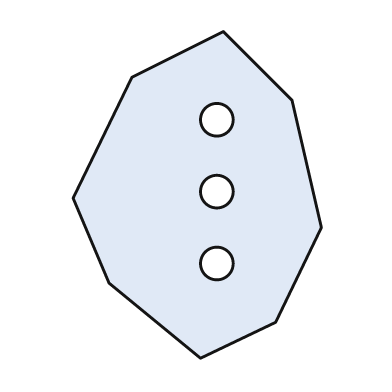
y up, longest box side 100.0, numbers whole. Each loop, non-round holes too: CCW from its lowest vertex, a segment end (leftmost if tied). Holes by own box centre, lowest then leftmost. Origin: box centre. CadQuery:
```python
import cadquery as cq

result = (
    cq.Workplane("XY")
    .moveTo(1.0, -50.0)
    .lineTo(24.0, -39.0)
    .lineTo(38.0, -10.0)
    .lineTo(29.0, 29.0)
    .lineTo(8.0, 50.0)
    .lineTo(-20.0, 36.0)
    .lineTo(-38.0, -1.0)
    .lineTo(-27.0, -27.0)
    .close()
    .moveTo(6.0, -21.0)
    .circle(5.0)
    .moveTo(6.0, 1.0)
    .circle(5.0)
    .moveTo(6.0, 23.0)
    .circle(5.0)
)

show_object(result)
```